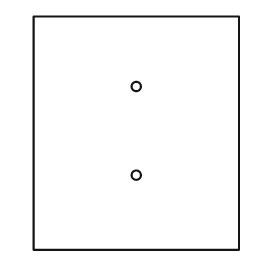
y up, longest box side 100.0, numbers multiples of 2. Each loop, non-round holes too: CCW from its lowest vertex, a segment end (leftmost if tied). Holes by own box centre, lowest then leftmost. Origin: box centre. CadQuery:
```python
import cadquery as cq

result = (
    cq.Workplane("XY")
    .moveTo(-44.0, -50.0)
    .lineTo(44.0, -50.0)
    .lineTo(44.0, 50.0)
    .lineTo(-44.0, 50.0)
    .close()
    .moveTo(0.0, -18.0)
    .circle(2.0)
    .moveTo(0.0, 20.0)
    .circle(2.0)
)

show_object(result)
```